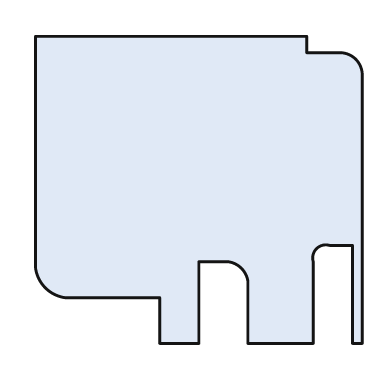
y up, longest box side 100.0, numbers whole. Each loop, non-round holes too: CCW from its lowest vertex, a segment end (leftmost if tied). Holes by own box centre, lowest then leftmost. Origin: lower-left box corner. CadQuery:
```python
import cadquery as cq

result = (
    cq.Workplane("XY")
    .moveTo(38.0, 0.0)
    .lineTo(50.0, 0.0)
    .lineTo(50.0, 25.0)
    .lineTo(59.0, 25.0)
    .threePointArc((63.0, 23.0), (65.0, 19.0))
    .lineTo(65.0, 0.0)
    .lineTo(85.0, 0.0)
    .lineTo(85.0, 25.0)
    .threePointArc((86.0, 29.0), (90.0, 30.0))
    .lineTo(97.0, 30.0)
    .lineTo(97.0, 0.0)
    .lineTo(100.0, 0.0)
    .lineTo(100.0, 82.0)
    .threePointArc((98.0, 87.0), (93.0, 89.0))
    .lineTo(83.0, 89.0)
    .lineTo(83.0, 94.0)
    .lineTo(0.0, 94.0)
    .lineTo(0.0, 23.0)
    .threePointArc((3.0, 17.0), (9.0, 14.0))
    .lineTo(38.0, 14.0)
    .close()
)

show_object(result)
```